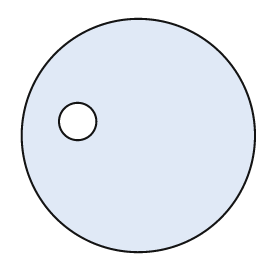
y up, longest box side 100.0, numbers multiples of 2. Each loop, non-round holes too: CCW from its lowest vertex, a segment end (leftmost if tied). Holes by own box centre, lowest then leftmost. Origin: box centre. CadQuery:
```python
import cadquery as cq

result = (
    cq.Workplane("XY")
    .moveTo(0.0, 0.0)
    .circle(50.0)
    .moveTo(-26.0, 6.0)
    .circle(8.0)
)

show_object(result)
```